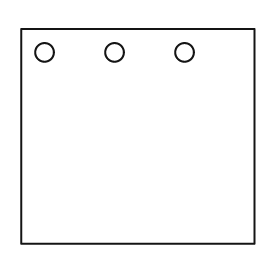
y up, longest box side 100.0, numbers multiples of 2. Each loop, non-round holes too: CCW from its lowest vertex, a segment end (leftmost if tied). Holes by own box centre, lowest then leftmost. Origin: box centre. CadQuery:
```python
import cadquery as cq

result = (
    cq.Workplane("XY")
    .moveTo(-50.0, -46.0)
    .lineTo(50.0, -46.0)
    .lineTo(50.0, 46.0)
    .lineTo(-50.0, 46.0)
    .close()
    .moveTo(-40.0, 36.0)
    .circle(4.0)
    .moveTo(-10.0, 36.0)
    .circle(4.0)
    .moveTo(20.0, 36.0)
    .circle(4.0)
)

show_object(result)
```